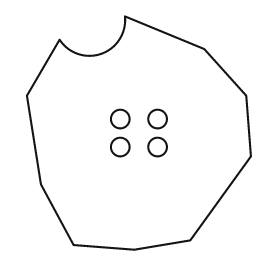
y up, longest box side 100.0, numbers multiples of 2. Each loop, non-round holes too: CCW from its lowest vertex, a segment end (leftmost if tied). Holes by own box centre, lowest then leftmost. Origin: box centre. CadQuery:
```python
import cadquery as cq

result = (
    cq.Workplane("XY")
    .moveTo(-2.0, -50.0)
    .lineTo(22.0, -46.0)
    .lineTo(48.0, -10.0)
    .lineTo(46.0, 16.0)
    .lineTo(28.0, 36.0)
    .lineTo(-6.0, 50.0)
    .threePointArc((-16.0, 34.0), (-34.0, 40.0))
    .lineTo(-48.0, 16.0)
    .lineTo(-42.0, -22.0)
    .lineTo(-28.0, -48.0)
    .close()
    .moveTo(-8.0, -6.0)
    .circle(4.0)
    .moveTo(8.0, -6.0)
    .circle(4.0)
    .moveTo(-8.0, 6.0)
    .circle(4.0)
    .moveTo(8.0, 6.0)
    .circle(4.0)
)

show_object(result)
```